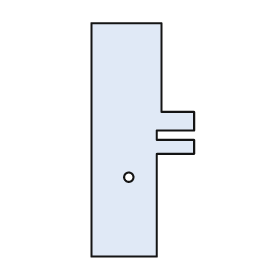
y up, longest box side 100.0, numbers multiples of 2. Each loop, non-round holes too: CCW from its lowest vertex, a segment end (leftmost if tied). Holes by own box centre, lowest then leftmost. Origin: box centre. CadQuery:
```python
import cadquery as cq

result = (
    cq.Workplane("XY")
    .moveTo(-22.0, -50.0)
    .lineTo(6.0, -50.0)
    .lineTo(6.0, -6.0)
    .lineTo(22.0, -6.0)
    .lineTo(22.0, 0.0)
    .lineTo(6.0, 0.0)
    .lineTo(6.0, 4.0)
    .lineTo(22.0, 4.0)
    .lineTo(22.0, 12.0)
    .lineTo(8.0, 12.0)
    .lineTo(8.0, 50.0)
    .lineTo(-22.0, 50.0)
    .close()
    .moveTo(-6.0, -16.0)
    .circle(2.0)
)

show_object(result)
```